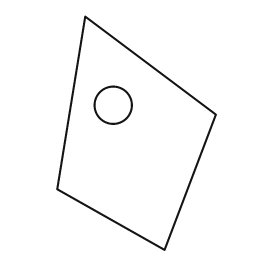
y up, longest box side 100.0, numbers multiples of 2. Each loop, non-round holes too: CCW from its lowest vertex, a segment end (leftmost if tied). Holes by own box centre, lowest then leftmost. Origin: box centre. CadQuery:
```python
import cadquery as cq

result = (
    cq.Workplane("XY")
    .moveTo(12.0, -50.0)
    .lineTo(34.0, 8.0)
    .lineTo(-22.0, 50.0)
    .lineTo(-34.0, -24.0)
    .close()
    .moveTo(-10.0, 12.0)
    .circle(8.0)
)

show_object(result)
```